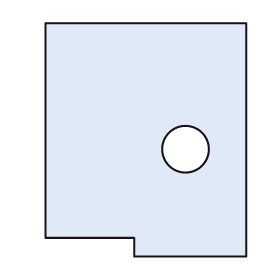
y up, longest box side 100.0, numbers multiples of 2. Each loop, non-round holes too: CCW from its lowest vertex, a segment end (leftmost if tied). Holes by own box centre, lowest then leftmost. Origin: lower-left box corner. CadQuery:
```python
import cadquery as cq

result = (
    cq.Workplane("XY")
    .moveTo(38.0, 0.0)
    .lineTo(86.0, 0.0)
    .lineTo(86.0, 100.0)
    .lineTo(0.0, 100.0)
    .lineTo(0.0, 8.0)
    .lineTo(38.0, 8.0)
    .close()
    .moveTo(60.0, 46.0)
    .circle(10.0)
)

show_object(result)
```